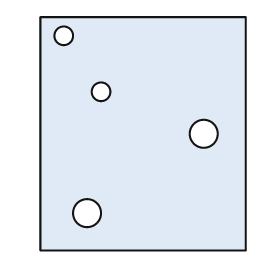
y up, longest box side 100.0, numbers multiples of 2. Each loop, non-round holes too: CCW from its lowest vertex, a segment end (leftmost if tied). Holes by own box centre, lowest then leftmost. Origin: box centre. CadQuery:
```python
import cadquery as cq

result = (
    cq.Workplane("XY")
    .moveTo(-44.0, -50.0)
    .lineTo(44.0, -50.0)
    .lineTo(44.0, 50.0)
    .lineTo(-44.0, 50.0)
    .close()
    .moveTo(-24.0, -34.0)
    .circle(6.0)
    .moveTo(26.0, 0.0)
    .circle(6.0)
    .moveTo(-18.0, 18.0)
    .circle(4.0)
    .moveTo(-34.0, 42.0)
    .circle(4.0)
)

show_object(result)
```